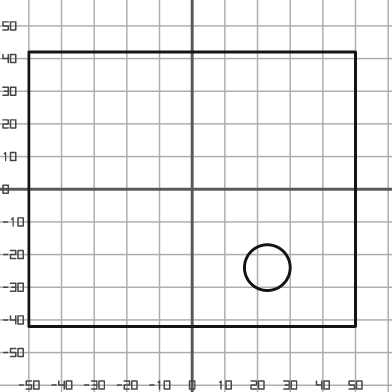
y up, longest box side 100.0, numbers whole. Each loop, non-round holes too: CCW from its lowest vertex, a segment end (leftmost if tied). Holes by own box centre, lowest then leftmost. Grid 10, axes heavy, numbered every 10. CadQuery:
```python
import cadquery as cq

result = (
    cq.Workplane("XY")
    .moveTo(-50.0, -42.0)
    .lineTo(50.0, -42.0)
    .lineTo(50.0, 42.0)
    .lineTo(-50.0, 42.0)
    .close()
    .moveTo(23.0, -24.0)
    .circle(7.0)
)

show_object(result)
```